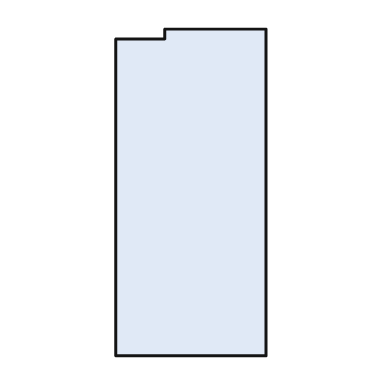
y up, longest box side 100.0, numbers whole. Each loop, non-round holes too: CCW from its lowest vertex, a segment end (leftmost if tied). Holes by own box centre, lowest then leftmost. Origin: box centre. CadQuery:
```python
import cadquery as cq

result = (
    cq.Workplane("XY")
    .moveTo(-23.0, -50.0)
    .lineTo(23.0, -50.0)
    .lineTo(23.0, 50.0)
    .lineTo(-8.0, 50.0)
    .lineTo(-8.0, 47.0)
    .lineTo(-23.0, 47.0)
    .close()
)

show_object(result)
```